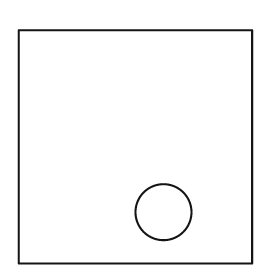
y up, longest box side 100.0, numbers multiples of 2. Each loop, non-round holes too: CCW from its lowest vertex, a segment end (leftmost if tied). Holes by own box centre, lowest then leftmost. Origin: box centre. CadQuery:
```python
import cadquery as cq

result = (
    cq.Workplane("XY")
    .moveTo(-50.0, -50.0)
    .lineTo(50.0, -50.0)
    .lineTo(50.0, 50.0)
    .lineTo(-50.0, 50.0)
    .close()
    .moveTo(12.0, -28.0)
    .circle(12.0)
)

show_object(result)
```